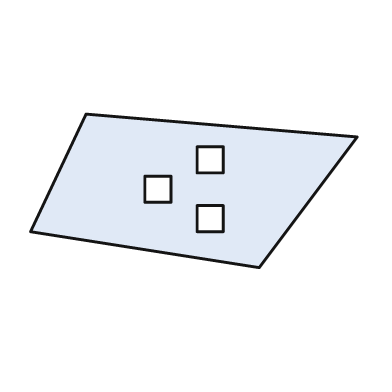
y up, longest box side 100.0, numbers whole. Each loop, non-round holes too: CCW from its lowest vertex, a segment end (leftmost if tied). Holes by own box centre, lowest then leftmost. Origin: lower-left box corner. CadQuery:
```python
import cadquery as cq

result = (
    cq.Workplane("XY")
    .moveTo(70.0, 0.0)
    .lineTo(100.0, 40.0)
    .lineTo(17.0, 47.0)
    .lineTo(0.0, 11.0)
    .close()
    .moveTo(51.0, 11.0)
    .lineTo(59.0, 11.0)
    .lineTo(59.0, 19.0)
    .lineTo(51.0, 19.0)
    .close()
    .moveTo(35.0, 20.0)
    .lineTo(43.0, 20.0)
    .lineTo(43.0, 28.0)
    .lineTo(35.0, 28.0)
    .close()
    .moveTo(51.0, 29.0)
    .lineTo(59.0, 29.0)
    .lineTo(59.0, 37.0)
    .lineTo(51.0, 37.0)
    .close()
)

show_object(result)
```